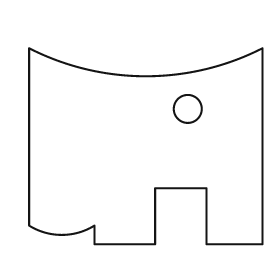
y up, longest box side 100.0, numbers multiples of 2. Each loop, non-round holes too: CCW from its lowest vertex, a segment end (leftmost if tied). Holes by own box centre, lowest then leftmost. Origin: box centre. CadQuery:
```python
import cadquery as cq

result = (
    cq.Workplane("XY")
    .moveTo(-22.0, -42.0)
    .lineTo(4.0, -42.0)
    .lineTo(4.0, -18.0)
    .lineTo(26.0, -18.0)
    .lineTo(26.0, -42.0)
    .lineTo(50.0, -42.0)
    .lineTo(50.0, 42.0)
    .threePointArc((0.0, 30.0), (-50.0, 42.0))
    .lineTo(-50.0, -34.0)
    .threePointArc((-36.0, -38.0), (-22.0, -34.0))
    .close()
    .moveTo(18.0, 16.0)
    .circle(6.0)
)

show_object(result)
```